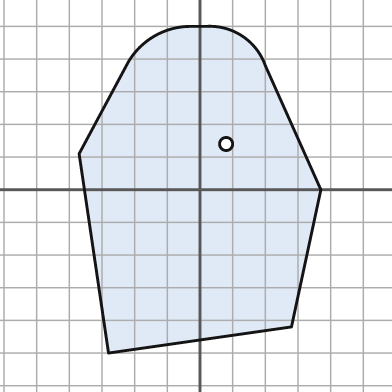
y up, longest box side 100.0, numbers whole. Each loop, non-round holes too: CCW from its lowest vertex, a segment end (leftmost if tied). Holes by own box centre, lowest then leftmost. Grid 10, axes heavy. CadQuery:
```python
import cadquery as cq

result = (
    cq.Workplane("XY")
    .moveTo(-28.0, -50.0)
    .lineTo(28.0, -42.0)
    .lineTo(37.0, 0.0)
    .lineTo(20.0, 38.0)
    .threePointArc((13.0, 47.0), (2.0, 50.0))
    .lineTo(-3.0, 50.0)
    .threePointArc((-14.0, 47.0), (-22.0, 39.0))
    .lineTo(-37.0, 11.0)
    .close()
    .moveTo(8.0, 14.0)
    .circle(2.0)
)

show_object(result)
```